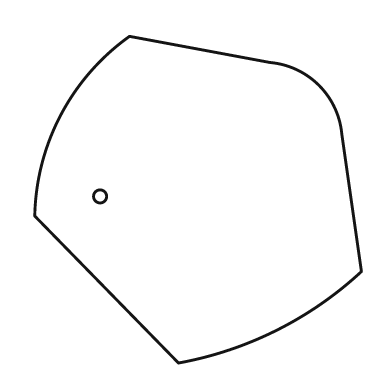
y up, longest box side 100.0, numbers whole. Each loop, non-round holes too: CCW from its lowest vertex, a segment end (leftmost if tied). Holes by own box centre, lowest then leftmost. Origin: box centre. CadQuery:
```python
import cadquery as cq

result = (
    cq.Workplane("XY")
    .moveTo(-6.0, -50.0)
    .threePointArc((24.0, -40.0), (50.0, -22.0))
    .lineTo(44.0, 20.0)
    .threePointArc((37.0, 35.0), (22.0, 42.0))
    .lineTo(-21.0, 50.0)
    .threePointArc((-42.0, 26.0), (-50.0, -5.0))
    .close()
    .moveTo(-30.0, 1.0)
    .circle(2.0)
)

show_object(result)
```